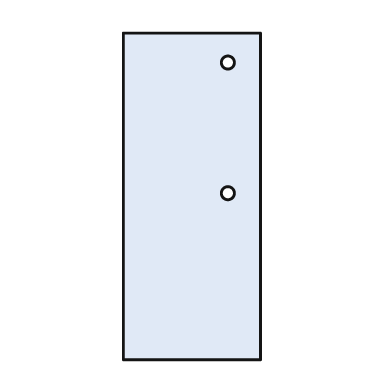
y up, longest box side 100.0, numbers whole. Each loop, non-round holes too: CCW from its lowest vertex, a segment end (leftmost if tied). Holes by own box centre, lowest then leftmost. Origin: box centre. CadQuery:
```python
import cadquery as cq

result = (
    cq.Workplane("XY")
    .moveTo(-21.0, -50.0)
    .lineTo(21.0, -50.0)
    .lineTo(21.0, 50.0)
    .lineTo(-21.0, 50.0)
    .close()
    .moveTo(11.0, 1.0)
    .circle(2.0)
    .moveTo(11.0, 41.0)
    .circle(2.0)
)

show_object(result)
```